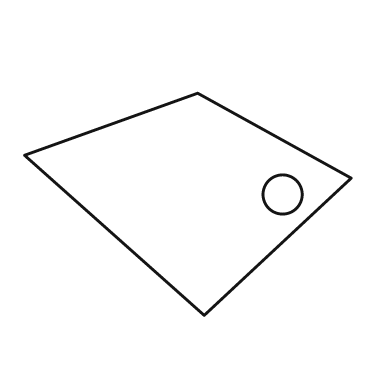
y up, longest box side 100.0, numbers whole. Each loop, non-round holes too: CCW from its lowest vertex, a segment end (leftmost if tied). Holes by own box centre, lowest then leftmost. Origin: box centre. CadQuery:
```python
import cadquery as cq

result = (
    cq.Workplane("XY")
    .moveTo(5.0, -34.0)
    .lineTo(50.0, 8.0)
    .lineTo(3.0, 34.0)
    .lineTo(-50.0, 15.0)
    .close()
    .moveTo(29.0, 3.0)
    .circle(6.0)
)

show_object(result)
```